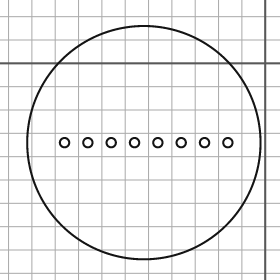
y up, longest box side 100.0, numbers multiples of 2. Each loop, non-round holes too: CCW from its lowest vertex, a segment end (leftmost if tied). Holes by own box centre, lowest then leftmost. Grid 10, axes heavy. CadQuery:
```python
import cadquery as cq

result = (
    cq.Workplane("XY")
    .moveTo(-52.0, -34.0)
    .circle(50.0)
    .moveTo(-86.0, -34.0)
    .circle(2.0)
    .moveTo(-76.0, -34.0)
    .circle(2.0)
    .moveTo(-66.0, -34.0)
    .circle(2.0)
    .moveTo(-56.0, -34.0)
    .circle(2.0)
    .moveTo(-46.0, -34.0)
    .circle(2.0)
    .moveTo(-36.0, -34.0)
    .circle(2.0)
    .moveTo(-26.0, -34.0)
    .circle(2.0)
    .moveTo(-16.0, -34.0)
    .circle(2.0)
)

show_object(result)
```